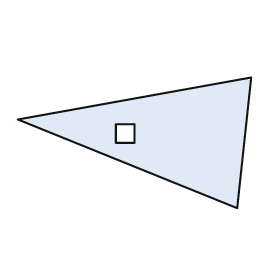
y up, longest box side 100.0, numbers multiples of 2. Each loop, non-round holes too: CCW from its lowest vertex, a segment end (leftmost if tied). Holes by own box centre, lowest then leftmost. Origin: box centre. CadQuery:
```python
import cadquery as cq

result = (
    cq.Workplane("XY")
    .moveTo(44.0, -28.0)
    .lineTo(50.0, 28.0)
    .lineTo(-50.0, 10.0)
    .close()
    .moveTo(-8.0, 0.0)
    .lineTo(0.0, 0.0)
    .lineTo(0.0, 8.0)
    .lineTo(-8.0, 8.0)
    .close()
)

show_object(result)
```